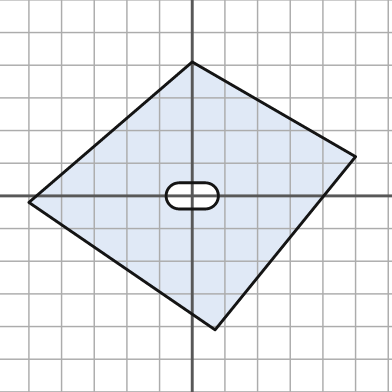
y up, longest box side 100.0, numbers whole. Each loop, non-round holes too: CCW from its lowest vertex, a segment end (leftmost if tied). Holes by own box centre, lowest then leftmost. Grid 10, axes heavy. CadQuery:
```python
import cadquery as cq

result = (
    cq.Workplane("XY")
    .moveTo(7.0, -41.0)
    .lineTo(50.0, 12.0)
    .lineTo(0.0, 41.0)
    .lineTo(-50.0, -2.0)
    .close()
    .moveTo(-4.0, -4.0)
    .lineTo(4.0, -4.0)
    .threePointArc((8.0, 0.0), (4.0, 4.0))
    .lineTo(-4.0, 4.0)
    .threePointArc((-8.0, 0.0), (-4.0, -4.0))
    .close()
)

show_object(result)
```